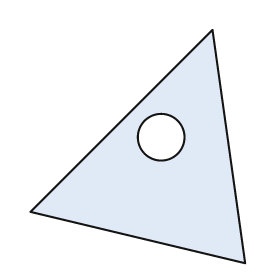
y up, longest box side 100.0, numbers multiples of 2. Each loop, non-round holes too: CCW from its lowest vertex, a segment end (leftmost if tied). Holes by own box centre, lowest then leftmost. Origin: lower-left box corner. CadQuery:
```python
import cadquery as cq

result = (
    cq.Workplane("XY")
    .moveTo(92.0, 0.0)
    .lineTo(78.0, 100.0)
    .lineTo(0.0, 22.0)
    .close()
    .moveTo(56.0, 54.0)
    .circle(10.0)
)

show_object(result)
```